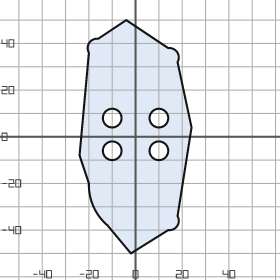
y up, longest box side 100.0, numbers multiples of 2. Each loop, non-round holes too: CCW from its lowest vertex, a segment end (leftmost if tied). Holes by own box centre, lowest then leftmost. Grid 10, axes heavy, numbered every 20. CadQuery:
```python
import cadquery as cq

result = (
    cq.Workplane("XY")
    .moveTo(-2.0, -50.0)
    .lineTo(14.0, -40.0)
    .threePointArc((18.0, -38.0), (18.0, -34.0))
    .lineTo(24.0, 4.0)
    .lineTo(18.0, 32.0)
    .threePointArc((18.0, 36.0), (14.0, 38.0))
    .lineTo(-4.0, 50.0)
    .lineTo(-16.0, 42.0)
    .threePointArc((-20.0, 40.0), (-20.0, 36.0))
    .lineTo(-24.0, -8.0)
    .lineTo(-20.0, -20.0)
    .threePointArc((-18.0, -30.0), (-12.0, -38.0))
    .close()
    .moveTo(-10.0, -6.0)
    .circle(4.0)
    .moveTo(10.0, -6.0)
    .circle(4.0)
    .moveTo(-10.0, 8.0)
    .circle(4.0)
    .moveTo(10.0, 8.0)
    .circle(4.0)
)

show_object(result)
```